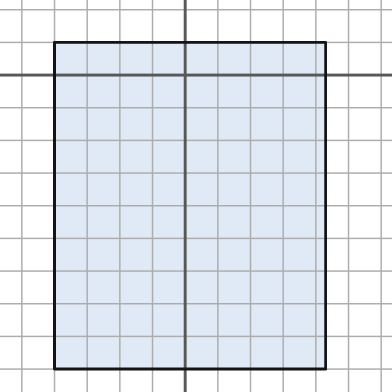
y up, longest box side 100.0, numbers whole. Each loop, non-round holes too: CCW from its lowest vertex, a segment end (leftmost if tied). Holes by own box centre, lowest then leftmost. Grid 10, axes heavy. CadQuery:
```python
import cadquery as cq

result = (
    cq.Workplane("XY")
    .moveTo(-40.0, -90.0)
    .lineTo(43.0, -90.0)
    .lineTo(43.0, 10.0)
    .lineTo(-40.0, 10.0)
    .close()
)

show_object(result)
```